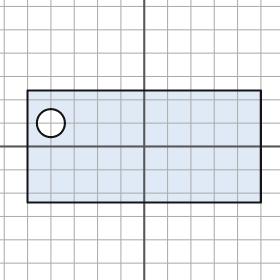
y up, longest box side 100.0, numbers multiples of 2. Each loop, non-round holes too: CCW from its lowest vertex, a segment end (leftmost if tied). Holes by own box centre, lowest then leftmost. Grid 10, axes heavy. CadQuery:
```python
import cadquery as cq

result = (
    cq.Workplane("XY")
    .moveTo(-50.0, -24.0)
    .lineTo(50.0, -24.0)
    .lineTo(50.0, 24.0)
    .lineTo(-50.0, 24.0)
    .close()
    .moveTo(-40.0, 10.0)
    .circle(6.0)
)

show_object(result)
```